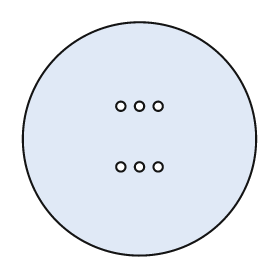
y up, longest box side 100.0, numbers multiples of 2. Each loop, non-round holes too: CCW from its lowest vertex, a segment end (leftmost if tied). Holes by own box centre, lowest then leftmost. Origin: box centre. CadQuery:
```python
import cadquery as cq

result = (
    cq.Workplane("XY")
    .moveTo(0.0, 0.0)
    .circle(50.0)
    .moveTo(-8.0, -12.0)
    .circle(2.0)
    .moveTo(0.0, -12.0)
    .circle(2.0)
    .moveTo(8.0, -12.0)
    .circle(2.0)
    .moveTo(-8.0, 14.0)
    .circle(2.0)
    .moveTo(0.0, 14.0)
    .circle(2.0)
    .moveTo(8.0, 14.0)
    .circle(2.0)
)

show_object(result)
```